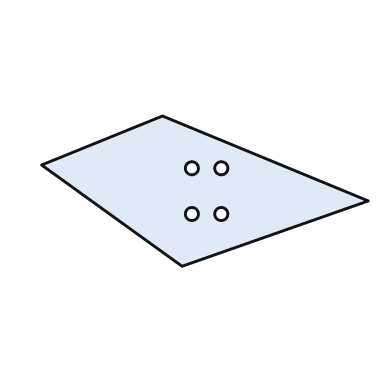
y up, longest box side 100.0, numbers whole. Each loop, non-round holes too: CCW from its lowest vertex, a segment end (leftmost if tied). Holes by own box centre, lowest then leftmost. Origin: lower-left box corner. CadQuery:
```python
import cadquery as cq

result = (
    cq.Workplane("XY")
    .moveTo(43.0, 0.0)
    .lineTo(100.0, 20.0)
    .lineTo(37.0, 46.0)
    .lineTo(0.0, 31.0)
    .close()
    .moveTo(46.0, 16.0)
    .circle(2.0)
    .moveTo(55.0, 16.0)
    .circle(2.0)
    .moveTo(46.0, 30.0)
    .circle(2.0)
    .moveTo(55.0, 30.0)
    .circle(2.0)
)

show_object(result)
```